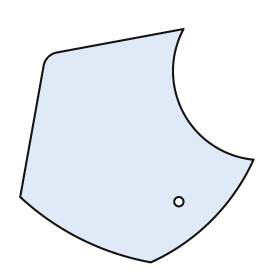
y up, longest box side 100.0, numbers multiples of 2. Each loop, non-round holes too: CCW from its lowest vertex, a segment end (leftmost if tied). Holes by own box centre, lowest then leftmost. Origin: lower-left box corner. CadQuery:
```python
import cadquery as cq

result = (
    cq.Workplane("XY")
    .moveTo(56.0, 0.0)
    .threePointArc((82.0, 18.0), (100.0, 44.0))
    .threePointArc((70.0, 64.0), (70.0, 100.0))
    .lineTo(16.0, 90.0)
    .threePointArc((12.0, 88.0), (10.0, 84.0))
    .lineTo(0.0, 28.0)
    .threePointArc((26.0, 10.0), (56.0, 0.0))
    .close()
    .moveTo(68.0, 26.0)
    .circle(2.0)
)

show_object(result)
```